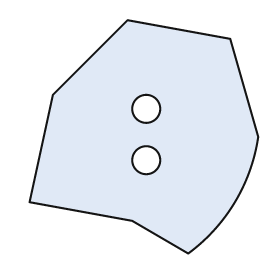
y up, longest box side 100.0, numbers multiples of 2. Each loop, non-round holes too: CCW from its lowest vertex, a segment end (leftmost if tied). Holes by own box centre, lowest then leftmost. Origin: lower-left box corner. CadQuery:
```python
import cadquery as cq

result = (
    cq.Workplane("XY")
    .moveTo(68.0, 0.0)
    .threePointArc((88.0, 22.0), (98.0, 50.0))
    .lineTo(86.0, 92.0)
    .lineTo(42.0, 100.0)
    .lineTo(10.0, 68.0)
    .lineTo(0.0, 22.0)
    .lineTo(44.0, 14.0)
    .close()
    .moveTo(50.0, 40.0)
    .circle(6.0)
    .moveTo(50.0, 62.0)
    .circle(6.0)
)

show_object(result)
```